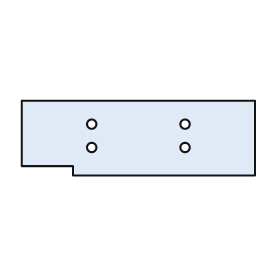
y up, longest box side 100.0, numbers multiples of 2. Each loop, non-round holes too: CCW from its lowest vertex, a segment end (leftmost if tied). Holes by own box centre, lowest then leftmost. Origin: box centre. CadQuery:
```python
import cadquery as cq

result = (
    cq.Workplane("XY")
    .moveTo(-28.0, -16.0)
    .lineTo(50.0, -16.0)
    .lineTo(50.0, 16.0)
    .lineTo(-50.0, 16.0)
    .lineTo(-50.0, -12.0)
    .lineTo(-28.0, -12.0)
    .close()
    .moveTo(-20.0, -4.0)
    .circle(2.0)
    .moveTo(20.0, -4.0)
    .circle(2.0)
    .moveTo(-20.0, 6.0)
    .circle(2.0)
    .moveTo(20.0, 6.0)
    .circle(2.0)
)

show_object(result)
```